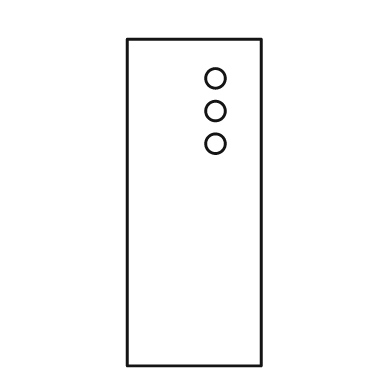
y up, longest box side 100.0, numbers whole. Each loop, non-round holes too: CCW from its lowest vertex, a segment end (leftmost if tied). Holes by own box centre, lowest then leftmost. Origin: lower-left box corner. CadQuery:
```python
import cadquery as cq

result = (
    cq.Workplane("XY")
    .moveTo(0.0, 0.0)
    .lineTo(41.0, 0.0)
    .lineTo(41.0, 100.0)
    .lineTo(0.0, 100.0)
    .close()
    .moveTo(27.0, 68.0)
    .circle(3.0)
    .moveTo(27.0, 78.0)
    .circle(3.0)
    .moveTo(27.0, 88.0)
    .circle(3.0)
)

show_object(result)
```